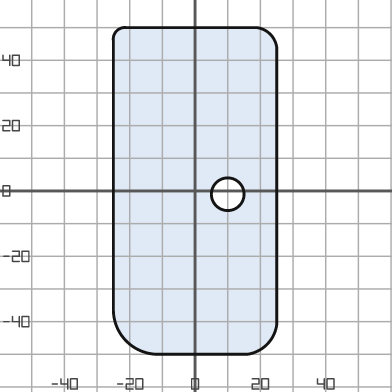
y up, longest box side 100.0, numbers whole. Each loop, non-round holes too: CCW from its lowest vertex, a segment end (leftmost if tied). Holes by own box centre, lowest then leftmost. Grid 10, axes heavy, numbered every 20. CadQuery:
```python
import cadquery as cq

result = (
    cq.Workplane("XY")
    .moveTo(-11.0, -50.0)
    .lineTo(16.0, -50.0)
    .threePointArc((22.0, -47.0), (25.0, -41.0))
    .lineTo(25.0, 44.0)
    .threePointArc((23.0, 48.0), (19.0, 50.0))
    .lineTo(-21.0, 50.0)
    .threePointArc((-24.0, 49.0), (-25.0, 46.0))
    .lineTo(-25.0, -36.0)
    .threePointArc((-21.0, -46.0), (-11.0, -50.0))
    .close()
    .moveTo(10.0, -1.0)
    .circle(5.0)
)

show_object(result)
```